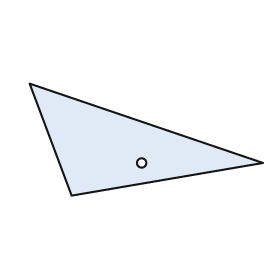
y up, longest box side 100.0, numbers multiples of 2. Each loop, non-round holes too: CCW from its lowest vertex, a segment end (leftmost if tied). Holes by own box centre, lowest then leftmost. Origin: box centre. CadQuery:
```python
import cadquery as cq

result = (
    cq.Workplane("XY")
    .moveTo(-32.0, -24.0)
    .lineTo(50.0, -10.0)
    .lineTo(-50.0, 24.0)
    .close()
    .moveTo(-2.0, -10.0)
    .circle(2.0)
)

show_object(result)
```